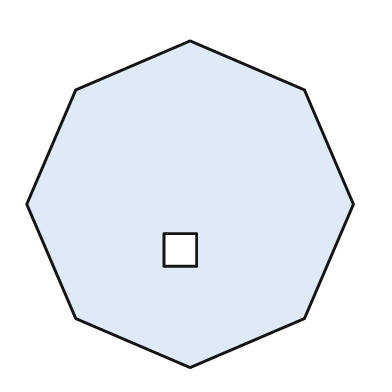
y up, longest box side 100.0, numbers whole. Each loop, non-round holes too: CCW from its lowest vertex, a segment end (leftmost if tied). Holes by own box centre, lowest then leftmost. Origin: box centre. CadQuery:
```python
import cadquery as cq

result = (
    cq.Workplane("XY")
    .moveTo(0.0, -50.0)
    .lineTo(35.0, -35.0)
    .lineTo(50.0, 0.0)
    .lineTo(35.0, 35.0)
    .lineTo(0.0, 50.0)
    .lineTo(-35.0, 35.0)
    .lineTo(-50.0, 0.0)
    .lineTo(-35.0, -35.0)
    .close()
    .moveTo(-8.0, -19.0)
    .lineTo(2.0, -19.0)
    .lineTo(2.0, -9.0)
    .lineTo(-8.0, -9.0)
    .close()
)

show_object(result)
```